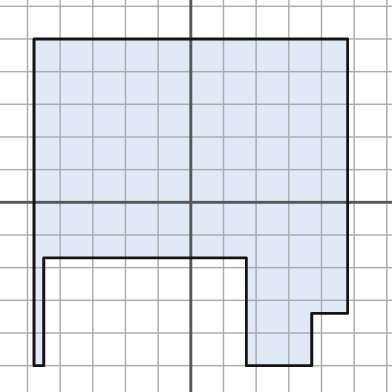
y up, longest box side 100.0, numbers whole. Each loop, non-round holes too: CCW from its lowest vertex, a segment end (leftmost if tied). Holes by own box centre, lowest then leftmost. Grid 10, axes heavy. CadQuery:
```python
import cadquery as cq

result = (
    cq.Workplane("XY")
    .moveTo(-48.0, -50.0)
    .lineTo(-45.0, -50.0)
    .lineTo(-45.0, -17.0)
    .lineTo(17.0, -17.0)
    .lineTo(17.0, -50.0)
    .lineTo(37.0, -50.0)
    .lineTo(37.0, -34.0)
    .lineTo(48.0, -34.0)
    .lineTo(48.0, 50.0)
    .lineTo(-48.0, 50.0)
    .close()
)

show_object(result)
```